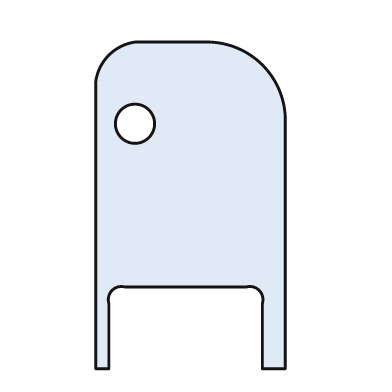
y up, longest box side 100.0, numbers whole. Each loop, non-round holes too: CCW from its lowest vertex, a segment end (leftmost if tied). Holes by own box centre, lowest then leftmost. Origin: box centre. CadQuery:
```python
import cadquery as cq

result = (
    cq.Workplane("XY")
    .moveTo(-29.0, -50.0)
    .lineTo(-25.0, -50.0)
    .lineTo(-25.0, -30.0)
    .threePointArc((-24.0, -26.0), (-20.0, -25.0))
    .lineTo(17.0, -25.0)
    .threePointArc((21.0, -26.0), (22.0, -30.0))
    .lineTo(22.0, -50.0)
    .lineTo(29.0, -50.0)
    .lineTo(29.0, 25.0)
    .threePointArc((22.0, 43.0), (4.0, 50.0))
    .lineTo(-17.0, 50.0)
    .threePointArc((-25.0, 46.0), (-29.0, 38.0))
    .close()
    .moveTo(-17.0, 25.0)
    .circle(6.0)
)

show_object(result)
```